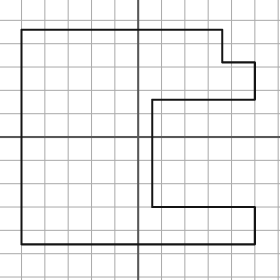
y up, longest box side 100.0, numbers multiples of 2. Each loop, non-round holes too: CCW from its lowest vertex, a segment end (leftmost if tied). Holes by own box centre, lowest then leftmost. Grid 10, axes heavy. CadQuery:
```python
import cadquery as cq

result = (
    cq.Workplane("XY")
    .moveTo(-50.0, -46.0)
    .lineTo(50.0, -46.0)
    .lineTo(50.0, -30.0)
    .lineTo(6.0, -30.0)
    .lineTo(6.0, 16.0)
    .lineTo(50.0, 16.0)
    .lineTo(50.0, 32.0)
    .lineTo(36.0, 32.0)
    .lineTo(36.0, 46.0)
    .lineTo(-50.0, 46.0)
    .close()
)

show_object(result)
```